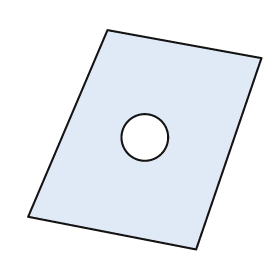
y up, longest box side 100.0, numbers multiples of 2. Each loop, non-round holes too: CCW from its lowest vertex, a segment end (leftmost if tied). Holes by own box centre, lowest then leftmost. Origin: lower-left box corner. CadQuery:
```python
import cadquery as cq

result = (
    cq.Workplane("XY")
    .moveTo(72.0, 0.0)
    .lineTo(100.0, 82.0)
    .lineTo(34.0, 94.0)
    .lineTo(0.0, 14.0)
    .close()
    .moveTo(50.0, 48.0)
    .circle(10.0)
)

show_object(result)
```